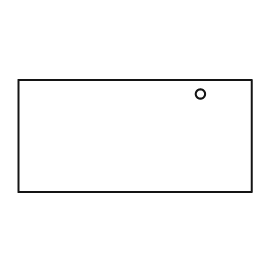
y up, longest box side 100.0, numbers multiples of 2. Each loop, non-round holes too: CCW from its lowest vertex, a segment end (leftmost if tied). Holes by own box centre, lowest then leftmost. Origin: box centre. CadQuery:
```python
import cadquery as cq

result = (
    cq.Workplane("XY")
    .moveTo(-50.0, -24.0)
    .lineTo(50.0, -24.0)
    .lineTo(50.0, 24.0)
    .lineTo(-50.0, 24.0)
    .close()
    .moveTo(28.0, 18.0)
    .circle(2.0)
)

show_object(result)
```